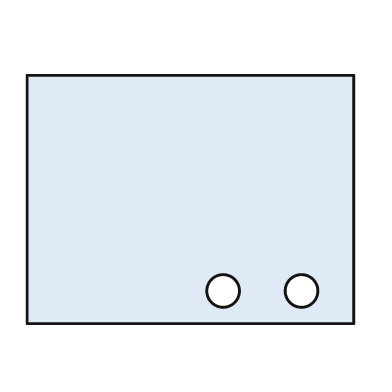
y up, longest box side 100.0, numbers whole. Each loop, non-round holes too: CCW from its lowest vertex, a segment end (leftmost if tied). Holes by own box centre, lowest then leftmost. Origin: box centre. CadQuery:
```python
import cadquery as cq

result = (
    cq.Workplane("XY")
    .moveTo(-50.0, -38.0)
    .lineTo(50.0, -38.0)
    .lineTo(50.0, 38.0)
    .lineTo(-50.0, 38.0)
    .close()
    .moveTo(10.0, -28.0)
    .circle(5.0)
    .moveTo(34.0, -28.0)
    .circle(5.0)
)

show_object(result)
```